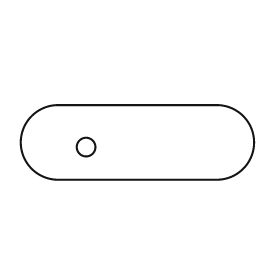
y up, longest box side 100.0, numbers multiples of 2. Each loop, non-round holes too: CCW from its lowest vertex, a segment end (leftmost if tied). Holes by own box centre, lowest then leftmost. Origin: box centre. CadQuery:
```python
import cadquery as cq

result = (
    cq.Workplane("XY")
    .moveTo(-34.0, -16.0)
    .lineTo(34.0, -16.0)
    .threePointArc((50.0, 0.0), (34.0, 16.0))
    .lineTo(-34.0, 16.0)
    .threePointArc((-50.0, 0.0), (-34.0, -16.0))
    .close()
    .moveTo(-22.0, -2.0)
    .circle(4.0)
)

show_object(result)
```